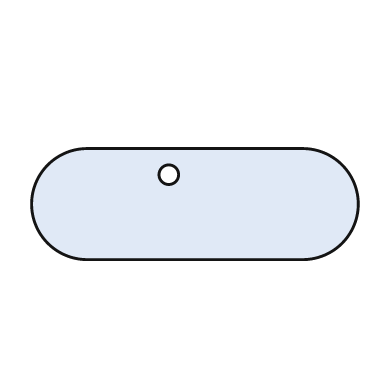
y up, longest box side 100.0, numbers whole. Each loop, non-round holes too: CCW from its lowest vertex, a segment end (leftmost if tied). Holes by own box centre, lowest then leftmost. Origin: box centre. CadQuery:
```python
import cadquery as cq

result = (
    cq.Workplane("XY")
    .moveTo(-33.0, -17.0)
    .lineTo(33.0, -17.0)
    .threePointArc((50.0, 0.0), (33.0, 17.0))
    .lineTo(-33.0, 17.0)
    .threePointArc((-50.0, 0.0), (-33.0, -17.0))
    .close()
    .moveTo(-8.0, 9.0)
    .circle(3.0)
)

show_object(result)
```